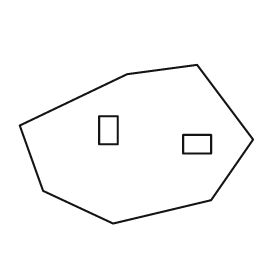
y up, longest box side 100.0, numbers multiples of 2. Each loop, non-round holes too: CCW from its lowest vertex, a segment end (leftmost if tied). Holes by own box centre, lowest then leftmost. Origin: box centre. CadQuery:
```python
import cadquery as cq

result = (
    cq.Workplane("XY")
    .moveTo(-10.0, -34.0)
    .lineTo(32.0, -24.0)
    .lineTo(50.0, 2.0)
    .lineTo(26.0, 34.0)
    .lineTo(-4.0, 30.0)
    .lineTo(-50.0, 8.0)
    .lineTo(-40.0, -20.0)
    .close()
    .moveTo(20.0, -4.0)
    .lineTo(32.0, -4.0)
    .lineTo(32.0, 4.0)
    .lineTo(20.0, 4.0)
    .close()
    .moveTo(-16.0, 0.0)
    .lineTo(-8.0, 0.0)
    .lineTo(-8.0, 12.0)
    .lineTo(-16.0, 12.0)
    .close()
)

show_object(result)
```